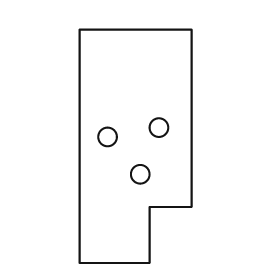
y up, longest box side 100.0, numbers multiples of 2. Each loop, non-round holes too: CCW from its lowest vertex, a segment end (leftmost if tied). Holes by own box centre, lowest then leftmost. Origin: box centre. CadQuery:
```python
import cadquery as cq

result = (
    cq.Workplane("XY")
    .moveTo(-24.0, -50.0)
    .lineTo(6.0, -50.0)
    .lineTo(6.0, -26.0)
    .lineTo(24.0, -26.0)
    .lineTo(24.0, 50.0)
    .lineTo(-24.0, 50.0)
    .close()
    .moveTo(2.0, -12.0)
    .circle(4.0)
    .moveTo(-12.0, 4.0)
    .circle(4.0)
    .moveTo(10.0, 8.0)
    .circle(4.0)
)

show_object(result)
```